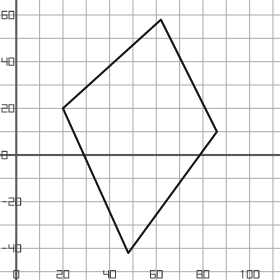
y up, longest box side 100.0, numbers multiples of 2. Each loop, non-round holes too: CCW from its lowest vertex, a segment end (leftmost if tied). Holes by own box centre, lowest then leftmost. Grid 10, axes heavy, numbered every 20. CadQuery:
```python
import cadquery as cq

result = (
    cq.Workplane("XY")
    .moveTo(48.0, -42.0)
    .lineTo(86.0, 10.0)
    .lineTo(62.0, 58.0)
    .lineTo(20.0, 20.0)
    .close()
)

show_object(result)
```